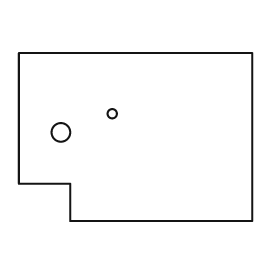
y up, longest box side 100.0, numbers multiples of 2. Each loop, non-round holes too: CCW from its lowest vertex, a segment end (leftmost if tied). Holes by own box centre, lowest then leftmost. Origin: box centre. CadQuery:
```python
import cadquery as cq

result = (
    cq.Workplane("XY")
    .moveTo(-28.0, -36.0)
    .lineTo(50.0, -36.0)
    .lineTo(50.0, 36.0)
    .lineTo(-50.0, 36.0)
    .lineTo(-50.0, -20.0)
    .lineTo(-28.0, -20.0)
    .close()
    .moveTo(-32.0, 2.0)
    .circle(4.0)
    .moveTo(-10.0, 10.0)
    .circle(2.0)
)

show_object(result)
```